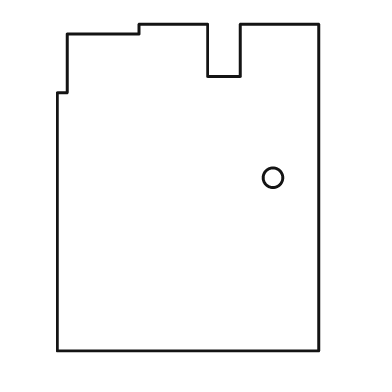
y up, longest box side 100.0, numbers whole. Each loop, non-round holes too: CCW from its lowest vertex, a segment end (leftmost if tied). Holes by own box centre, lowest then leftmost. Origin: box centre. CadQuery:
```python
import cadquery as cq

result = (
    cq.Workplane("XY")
    .moveTo(-40.0, -50.0)
    .lineTo(40.0, -50.0)
    .lineTo(40.0, 50.0)
    .lineTo(16.0, 50.0)
    .lineTo(16.0, 34.0)
    .lineTo(6.0, 34.0)
    .lineTo(6.0, 50.0)
    .lineTo(-15.0, 50.0)
    .lineTo(-15.0, 47.0)
    .lineTo(-37.0, 47.0)
    .lineTo(-37.0, 29.0)
    .lineTo(-40.0, 29.0)
    .close()
    .moveTo(26.0, 3.0)
    .circle(3.0)
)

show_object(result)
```